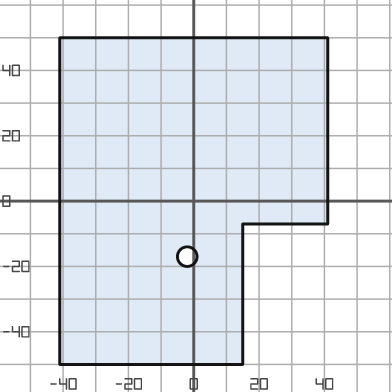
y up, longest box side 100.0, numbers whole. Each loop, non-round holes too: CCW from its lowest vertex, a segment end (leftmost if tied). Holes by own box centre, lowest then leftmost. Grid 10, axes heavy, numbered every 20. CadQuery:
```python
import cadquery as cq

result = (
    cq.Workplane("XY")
    .moveTo(-41.0, -50.0)
    .lineTo(15.0, -50.0)
    .lineTo(15.0, -7.0)
    .lineTo(41.0, -7.0)
    .lineTo(41.0, 50.0)
    .lineTo(-41.0, 50.0)
    .close()
    .moveTo(-2.0, -17.0)
    .circle(3.0)
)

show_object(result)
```